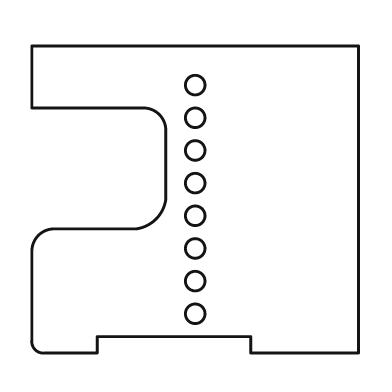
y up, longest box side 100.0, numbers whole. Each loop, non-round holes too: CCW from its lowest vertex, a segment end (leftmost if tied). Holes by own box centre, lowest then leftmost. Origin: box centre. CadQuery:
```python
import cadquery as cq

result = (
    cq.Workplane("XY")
    .moveTo(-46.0, -47.0)
    .lineTo(-30.0, -47.0)
    .lineTo(-30.0, -42.0)
    .lineTo(17.0, -42.0)
    .lineTo(17.0, -47.0)
    .lineTo(50.0, -47.0)
    .lineTo(50.0, 47.0)
    .lineTo(-50.0, 47.0)
    .lineTo(-50.0, 28.0)
    .lineTo(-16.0, 28.0)
    .threePointArc((-11.0, 26.0), (-9.0, 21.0))
    .lineTo(-9.0, 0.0)
    .threePointArc((-12.0, -6.0), (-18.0, -9.0))
    .lineTo(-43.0, -9.0)
    .threePointArc((-48.0, -11.0), (-50.0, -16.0))
    .lineTo(-50.0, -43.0)
    .threePointArc((-49.0, -46.0), (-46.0, -47.0))
    .close()
    .moveTo(0.0, -35.0)
    .circle(3.0)
    .moveTo(0.0, -25.0)
    .circle(3.0)
    .moveTo(0.0, -15.0)
    .circle(3.0)
    .moveTo(0.0, -5.0)
    .circle(3.0)
    .moveTo(0.0, 5.0)
    .circle(3.0)
    .moveTo(0.0, 15.0)
    .circle(3.0)
    .moveTo(0.0, 25.0)
    .circle(3.0)
    .moveTo(0.0, 35.0)
    .circle(3.0)
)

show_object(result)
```